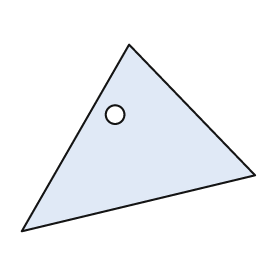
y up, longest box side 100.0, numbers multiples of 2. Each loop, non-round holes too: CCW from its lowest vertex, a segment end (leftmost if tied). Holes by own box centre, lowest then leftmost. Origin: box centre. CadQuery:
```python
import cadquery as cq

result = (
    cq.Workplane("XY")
    .moveTo(-50.0, -40.0)
    .lineTo(50.0, -16.0)
    .lineTo(-4.0, 40.0)
    .close()
    .moveTo(-10.0, 10.0)
    .circle(4.0)
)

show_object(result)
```